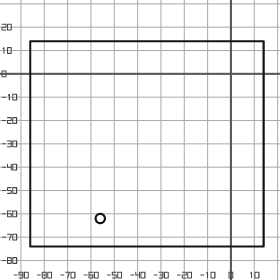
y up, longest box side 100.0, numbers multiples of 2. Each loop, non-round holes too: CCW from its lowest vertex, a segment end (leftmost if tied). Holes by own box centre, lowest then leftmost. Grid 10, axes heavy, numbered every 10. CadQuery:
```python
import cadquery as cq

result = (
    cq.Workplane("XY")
    .moveTo(-86.0, -74.0)
    .lineTo(14.0, -74.0)
    .lineTo(14.0, 14.0)
    .lineTo(-86.0, 14.0)
    .close()
    .moveTo(-56.0, -62.0)
    .circle(2.0)
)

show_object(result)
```